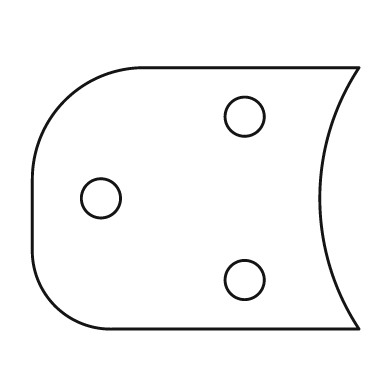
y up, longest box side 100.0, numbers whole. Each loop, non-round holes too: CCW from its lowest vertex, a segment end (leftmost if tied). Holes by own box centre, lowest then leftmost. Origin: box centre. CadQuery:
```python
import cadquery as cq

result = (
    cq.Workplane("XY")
    .moveTo(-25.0, -40.0)
    .lineTo(50.0, -40.0)
    .threePointArc((38.0, 0.0), (50.0, 40.0))
    .lineTo(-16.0, 40.0)
    .threePointArc((-40.0, 30.0), (-50.0, 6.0))
    .lineTo(-50.0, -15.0)
    .threePointArc((-43.0, -33.0), (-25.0, -40.0))
    .close()
    .moveTo(15.0, -25.0)
    .circle(6.0)
    .moveTo(-29.0, 0.0)
    .circle(6.0)
    .moveTo(15.0, 25.0)
    .circle(6.0)
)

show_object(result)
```